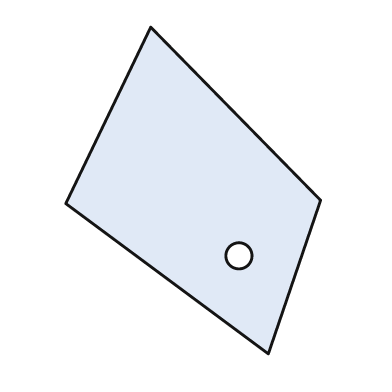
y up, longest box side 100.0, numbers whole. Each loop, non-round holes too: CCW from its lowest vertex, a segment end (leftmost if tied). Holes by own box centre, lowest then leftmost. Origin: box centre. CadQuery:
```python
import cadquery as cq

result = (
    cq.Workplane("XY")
    .moveTo(23.0, -50.0)
    .lineTo(39.0, -3.0)
    .lineTo(-13.0, 50.0)
    .lineTo(-39.0, -4.0)
    .close()
    .moveTo(14.0, -20.0)
    .circle(4.0)
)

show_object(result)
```